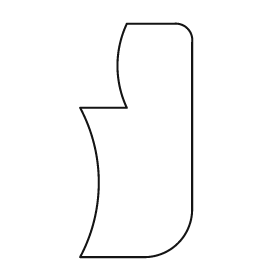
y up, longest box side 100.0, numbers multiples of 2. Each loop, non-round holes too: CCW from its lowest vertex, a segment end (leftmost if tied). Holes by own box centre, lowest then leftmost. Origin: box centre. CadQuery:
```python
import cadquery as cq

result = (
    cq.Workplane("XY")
    .moveTo(-24.0, -50.0)
    .lineTo(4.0, -50.0)
    .threePointArc((18.0, -44.0), (24.0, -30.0))
    .lineTo(24.0, 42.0)
    .threePointArc((22.0, 48.0), (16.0, 50.0))
    .lineTo(-4.0, 50.0)
    .threePointArc((-8.0, 32.0), (-4.0, 14.0))
    .lineTo(-24.0, 14.0)
    .threePointArc((-16.0, -18.0), (-24.0, -50.0))
    .close()
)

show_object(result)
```